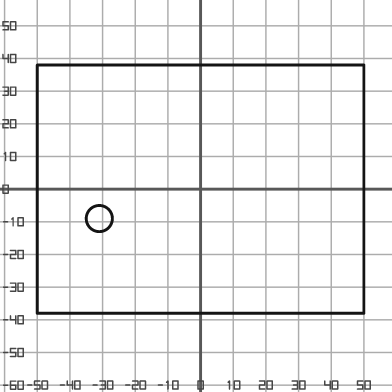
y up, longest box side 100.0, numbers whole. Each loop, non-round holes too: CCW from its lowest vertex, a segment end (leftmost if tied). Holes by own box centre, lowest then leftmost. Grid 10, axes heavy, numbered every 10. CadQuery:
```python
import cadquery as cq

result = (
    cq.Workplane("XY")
    .moveTo(-50.0, -38.0)
    .lineTo(50.0, -38.0)
    .lineTo(50.0, 38.0)
    .lineTo(-50.0, 38.0)
    .close()
    .moveTo(-31.0, -9.0)
    .circle(4.0)
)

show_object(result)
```